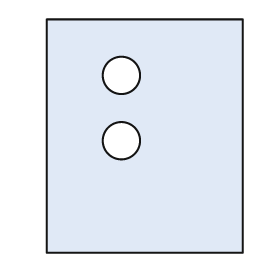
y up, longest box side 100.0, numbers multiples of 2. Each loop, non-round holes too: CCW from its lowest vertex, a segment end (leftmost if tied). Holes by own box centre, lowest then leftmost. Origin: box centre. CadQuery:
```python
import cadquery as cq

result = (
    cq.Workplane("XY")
    .moveTo(-42.0, -50.0)
    .lineTo(42.0, -50.0)
    .lineTo(42.0, 50.0)
    .lineTo(-42.0, 50.0)
    .close()
    .moveTo(-10.0, -2.0)
    .circle(8.0)
    .moveTo(-10.0, 26.0)
    .circle(8.0)
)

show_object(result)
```